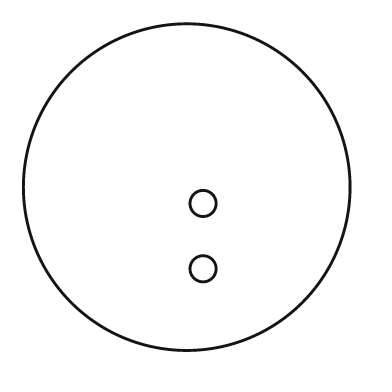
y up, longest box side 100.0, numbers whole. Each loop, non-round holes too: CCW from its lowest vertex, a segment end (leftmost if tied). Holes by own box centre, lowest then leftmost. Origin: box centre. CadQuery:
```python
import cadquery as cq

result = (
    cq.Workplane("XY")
    .moveTo(0.0, 0.0)
    .circle(50.0)
    .moveTo(5.0, -25.0)
    .circle(4.0)
    .moveTo(5.0, -5.0)
    .circle(4.0)
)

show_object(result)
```